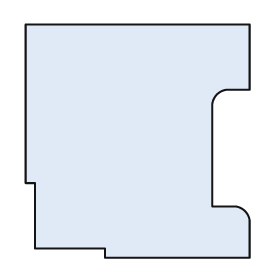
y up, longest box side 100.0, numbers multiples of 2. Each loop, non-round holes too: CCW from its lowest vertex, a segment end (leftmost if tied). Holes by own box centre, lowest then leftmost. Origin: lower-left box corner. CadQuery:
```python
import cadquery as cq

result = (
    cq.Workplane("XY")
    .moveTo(34.0, 0.0)
    .lineTo(96.0, 0.0)
    .lineTo(96.0, 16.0)
    .threePointArc((94.0, 20.0), (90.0, 22.0))
    .lineTo(80.0, 22.0)
    .lineTo(80.0, 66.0)
    .threePointArc((82.0, 70.0), (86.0, 72.0))
    .lineTo(96.0, 72.0)
    .lineTo(96.0, 100.0)
    .lineTo(0.0, 100.0)
    .lineTo(0.0, 32.0)
    .lineTo(4.0, 32.0)
    .lineTo(4.0, 4.0)
    .lineTo(34.0, 4.0)
    .close()
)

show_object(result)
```